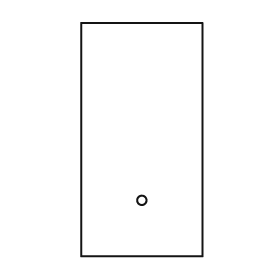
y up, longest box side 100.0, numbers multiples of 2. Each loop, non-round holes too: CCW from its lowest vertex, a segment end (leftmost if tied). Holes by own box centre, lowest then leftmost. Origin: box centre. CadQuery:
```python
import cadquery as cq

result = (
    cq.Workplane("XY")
    .moveTo(-26.0, -50.0)
    .lineTo(26.0, -50.0)
    .lineTo(26.0, 50.0)
    .lineTo(-26.0, 50.0)
    .close()
    .moveTo(0.0, -26.0)
    .circle(2.0)
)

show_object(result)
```